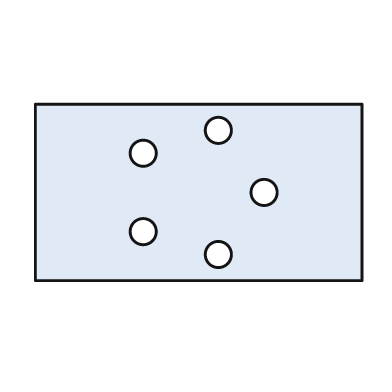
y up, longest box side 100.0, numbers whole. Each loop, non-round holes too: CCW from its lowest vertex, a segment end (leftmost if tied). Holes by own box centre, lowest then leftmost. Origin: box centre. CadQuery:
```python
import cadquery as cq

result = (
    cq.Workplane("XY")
    .moveTo(-50.0, -27.0)
    .lineTo(50.0, -27.0)
    .lineTo(50.0, 27.0)
    .lineTo(-50.0, 27.0)
    .close()
    .moveTo(6.0, -19.0)
    .circle(4.0)
    .moveTo(-17.0, -12.0)
    .circle(4.0)
    .moveTo(20.0, 0.0)
    .circle(4.0)
    .moveTo(-17.0, 12.0)
    .circle(4.0)
    .moveTo(6.0, 19.0)
    .circle(4.0)
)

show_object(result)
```